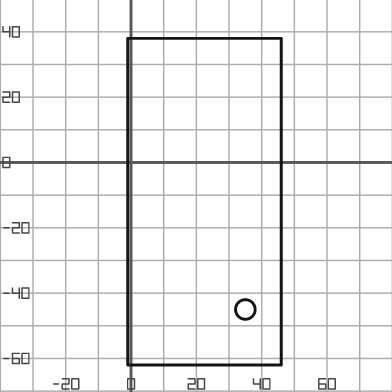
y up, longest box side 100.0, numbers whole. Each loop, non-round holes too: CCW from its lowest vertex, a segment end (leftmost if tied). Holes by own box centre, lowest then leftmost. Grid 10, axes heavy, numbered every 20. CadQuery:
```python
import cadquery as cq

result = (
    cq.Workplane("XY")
    .moveTo(-1.0, -62.0)
    .lineTo(46.0, -62.0)
    .lineTo(46.0, 38.0)
    .lineTo(-1.0, 38.0)
    .close()
    .moveTo(35.0, -45.0)
    .circle(3.0)
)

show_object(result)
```